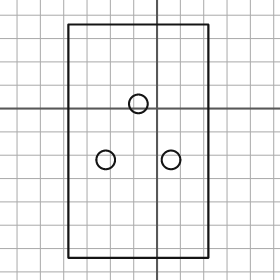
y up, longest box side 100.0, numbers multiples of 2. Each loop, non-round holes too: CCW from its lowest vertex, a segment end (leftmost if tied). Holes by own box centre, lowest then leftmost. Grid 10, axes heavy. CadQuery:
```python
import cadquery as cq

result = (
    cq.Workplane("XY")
    .moveTo(-38.0, -64.0)
    .lineTo(22.0, -64.0)
    .lineTo(22.0, 36.0)
    .lineTo(-38.0, 36.0)
    .close()
    .moveTo(-22.0, -22.0)
    .circle(4.0)
    .moveTo(6.0, -22.0)
    .circle(4.0)
    .moveTo(-8.0, 2.0)
    .circle(4.0)
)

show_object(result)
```